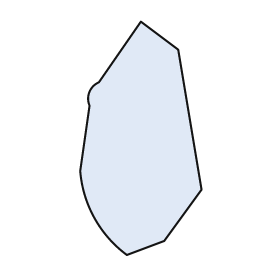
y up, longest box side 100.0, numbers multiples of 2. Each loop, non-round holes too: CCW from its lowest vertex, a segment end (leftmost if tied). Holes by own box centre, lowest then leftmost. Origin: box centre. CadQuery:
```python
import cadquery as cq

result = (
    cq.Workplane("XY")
    .moveTo(-6.0, -50.0)
    .lineTo(10.0, -44.0)
    .lineTo(26.0, -22.0)
    .lineTo(16.0, 38.0)
    .lineTo(0.0, 50.0)
    .lineTo(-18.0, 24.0)
    .threePointArc((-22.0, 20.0), (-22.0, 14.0))
    .lineTo(-26.0, -14.0)
    .threePointArc((-20.0, -34.0), (-6.0, -50.0))
    .close()
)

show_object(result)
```